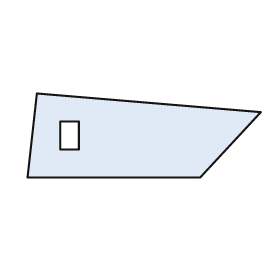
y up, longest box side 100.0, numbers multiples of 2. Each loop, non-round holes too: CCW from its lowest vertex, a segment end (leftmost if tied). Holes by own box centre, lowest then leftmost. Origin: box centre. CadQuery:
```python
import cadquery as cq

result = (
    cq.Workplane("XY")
    .moveTo(-50.0, -18.0)
    .lineTo(24.0, -18.0)
    .lineTo(50.0, 10.0)
    .lineTo(-46.0, 18.0)
    .close()
    .moveTo(-36.0, -6.0)
    .lineTo(-28.0, -6.0)
    .lineTo(-28.0, 6.0)
    .lineTo(-36.0, 6.0)
    .close()
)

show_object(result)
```